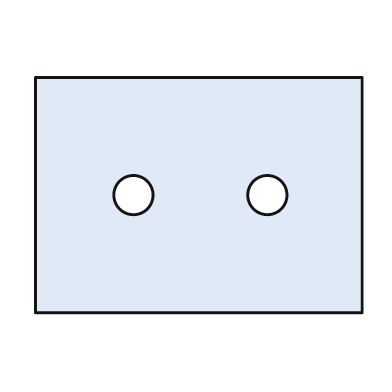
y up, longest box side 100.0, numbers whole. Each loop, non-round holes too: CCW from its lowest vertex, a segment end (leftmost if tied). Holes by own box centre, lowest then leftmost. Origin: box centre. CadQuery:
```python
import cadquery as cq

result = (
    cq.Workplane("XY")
    .moveTo(-50.0, -36.0)
    .lineTo(50.0, -36.0)
    .lineTo(50.0, 36.0)
    .lineTo(-50.0, 36.0)
    .close()
    .moveTo(-20.0, 0.0)
    .circle(6.0)
    .moveTo(21.0, 0.0)
    .circle(6.0)
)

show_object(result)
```